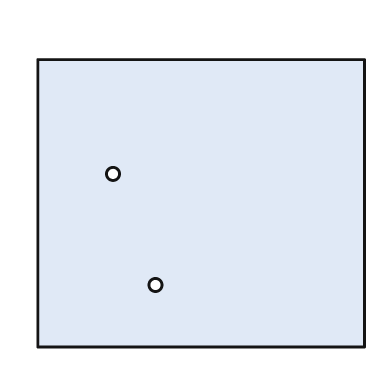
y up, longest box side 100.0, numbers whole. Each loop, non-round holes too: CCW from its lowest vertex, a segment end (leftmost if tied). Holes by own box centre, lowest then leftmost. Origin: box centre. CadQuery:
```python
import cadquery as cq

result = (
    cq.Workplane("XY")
    .moveTo(-50.0, -44.0)
    .lineTo(50.0, -44.0)
    .lineTo(50.0, 44.0)
    .lineTo(-50.0, 44.0)
    .close()
    .moveTo(-14.0, -25.0)
    .circle(2.0)
    .moveTo(-27.0, 9.0)
    .circle(2.0)
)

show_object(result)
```